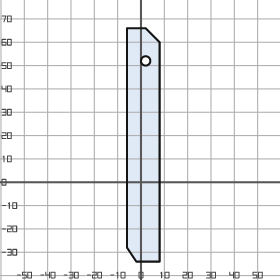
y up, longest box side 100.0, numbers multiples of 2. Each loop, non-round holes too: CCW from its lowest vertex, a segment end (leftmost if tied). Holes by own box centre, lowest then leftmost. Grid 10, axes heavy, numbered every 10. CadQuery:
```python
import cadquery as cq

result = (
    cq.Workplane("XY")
    .moveTo(-2.0, -34.0)
    .lineTo(8.0, -34.0)
    .lineTo(8.0, 60.0)
    .lineTo(2.0, 66.0)
    .lineTo(-6.0, 66.0)
    .lineTo(-6.0, -28.0)
    .close()
    .moveTo(2.0, 52.0)
    .circle(2.0)
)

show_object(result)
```